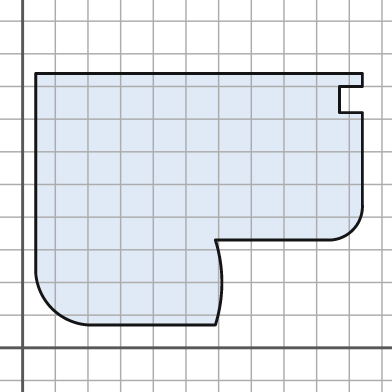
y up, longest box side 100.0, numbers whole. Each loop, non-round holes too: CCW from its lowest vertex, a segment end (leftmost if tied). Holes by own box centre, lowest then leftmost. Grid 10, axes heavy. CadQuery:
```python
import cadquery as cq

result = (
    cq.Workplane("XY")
    .moveTo(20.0, 7.0)
    .lineTo(59.0, 7.0)
    .threePointArc((61.0, 20.0), (59.0, 33.0))
    .lineTo(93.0, 33.0)
    .threePointArc((101.0, 36.0), (104.0, 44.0))
    .lineTo(104.0, 72.0)
    .lineTo(97.0, 72.0)
    .lineTo(97.0, 80.0)
    .lineTo(104.0, 80.0)
    .lineTo(104.0, 84.0)
    .lineTo(4.0, 84.0)
    .lineTo(4.0, 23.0)
    .threePointArc((9.0, 12.0), (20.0, 7.0))
    .close()
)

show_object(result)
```